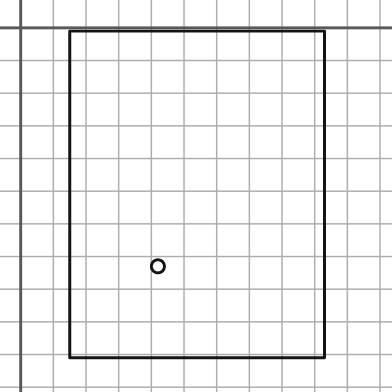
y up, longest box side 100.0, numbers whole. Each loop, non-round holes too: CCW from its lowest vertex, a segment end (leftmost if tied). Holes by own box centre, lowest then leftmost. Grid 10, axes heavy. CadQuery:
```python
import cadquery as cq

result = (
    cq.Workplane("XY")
    .moveTo(15.0, -101.0)
    .lineTo(93.0, -101.0)
    .lineTo(93.0, -1.0)
    .lineTo(15.0, -1.0)
    .close()
    .moveTo(42.0, -73.0)
    .circle(2.0)
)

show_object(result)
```